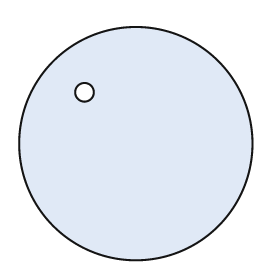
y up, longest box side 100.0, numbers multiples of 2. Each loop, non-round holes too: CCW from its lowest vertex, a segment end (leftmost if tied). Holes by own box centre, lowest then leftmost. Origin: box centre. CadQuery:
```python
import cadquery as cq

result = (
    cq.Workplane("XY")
    .moveTo(0.0, 0.0)
    .circle(50.0)
    .moveTo(-22.0, 22.0)
    .circle(4.0)
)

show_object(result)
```